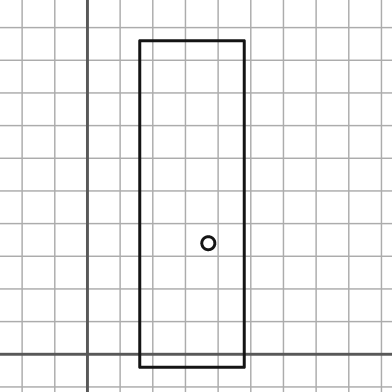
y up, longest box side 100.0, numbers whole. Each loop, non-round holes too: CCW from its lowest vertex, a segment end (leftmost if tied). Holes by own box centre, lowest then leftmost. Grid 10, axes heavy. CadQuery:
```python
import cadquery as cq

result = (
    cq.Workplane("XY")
    .moveTo(16.0, -4.0)
    .lineTo(48.0, -4.0)
    .lineTo(48.0, 96.0)
    .lineTo(16.0, 96.0)
    .close()
    .moveTo(37.0, 34.0)
    .circle(2.0)
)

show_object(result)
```